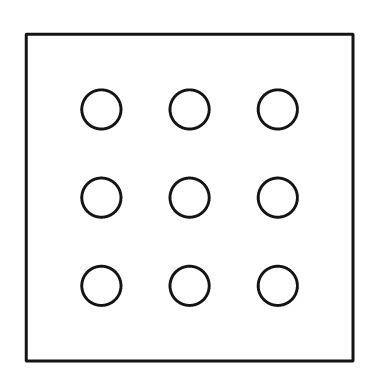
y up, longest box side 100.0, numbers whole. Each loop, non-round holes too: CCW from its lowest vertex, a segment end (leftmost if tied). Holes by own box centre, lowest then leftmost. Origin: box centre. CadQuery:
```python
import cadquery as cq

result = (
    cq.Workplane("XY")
    .moveTo(-50.0, -50.0)
    .lineTo(50.0, -50.0)
    .lineTo(50.0, 50.0)
    .lineTo(-50.0, 50.0)
    .close()
    .moveTo(-27.0, -27.0)
    .circle(6.0)
    .moveTo(0.0, -27.0)
    .circle(6.0)
    .moveTo(27.0, -27.0)
    .circle(6.0)
    .moveTo(-27.0, 0.0)
    .circle(6.0)
    .moveTo(0.0, 0.0)
    .circle(6.0)
    .moveTo(27.0, 0.0)
    .circle(6.0)
    .moveTo(-27.0, 27.0)
    .circle(6.0)
    .moveTo(0.0, 27.0)
    .circle(6.0)
    .moveTo(27.0, 27.0)
    .circle(6.0)
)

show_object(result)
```